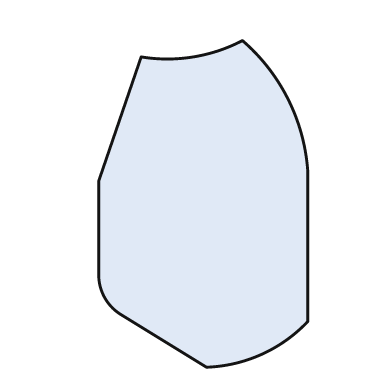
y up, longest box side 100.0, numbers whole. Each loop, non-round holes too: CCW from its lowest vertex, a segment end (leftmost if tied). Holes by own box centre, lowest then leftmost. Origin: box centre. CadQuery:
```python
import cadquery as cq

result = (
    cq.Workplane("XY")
    .moveTo(1.0, -50.0)
    .threePointArc((18.0, -46.0), (32.0, -36.0))
    .lineTo(32.0, 10.0)
    .threePointArc((26.0, 32.0), (12.0, 50.0))
    .threePointArc((-3.0, 45.0), (-19.0, 45.0))
    .lineTo(-32.0, 7.0)
    .lineTo(-32.0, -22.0)
    .threePointArc((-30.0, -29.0), (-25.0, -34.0))
    .close()
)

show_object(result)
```